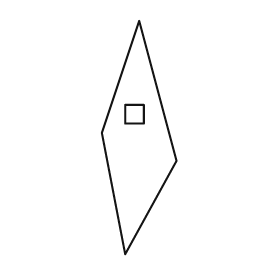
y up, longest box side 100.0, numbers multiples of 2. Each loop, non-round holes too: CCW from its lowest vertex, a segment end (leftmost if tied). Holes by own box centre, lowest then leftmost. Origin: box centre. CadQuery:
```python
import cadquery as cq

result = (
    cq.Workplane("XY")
    .moveTo(-6.0, -50.0)
    .lineTo(16.0, -10.0)
    .lineTo(0.0, 50.0)
    .lineTo(-16.0, 2.0)
    .close()
    .moveTo(-6.0, 6.0)
    .lineTo(2.0, 6.0)
    .lineTo(2.0, 14.0)
    .lineTo(-6.0, 14.0)
    .close()
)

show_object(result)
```